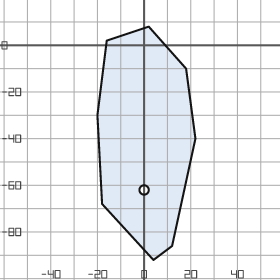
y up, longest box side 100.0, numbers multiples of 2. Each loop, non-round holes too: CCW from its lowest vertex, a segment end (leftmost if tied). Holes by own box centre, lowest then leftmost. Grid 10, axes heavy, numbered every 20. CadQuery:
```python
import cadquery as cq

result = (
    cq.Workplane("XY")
    .moveTo(4.0, -92.0)
    .lineTo(12.0, -86.0)
    .lineTo(22.0, -40.0)
    .lineTo(18.0, -10.0)
    .lineTo(2.0, 8.0)
    .lineTo(-16.0, 2.0)
    .lineTo(-20.0, -30.0)
    .lineTo(-18.0, -68.0)
    .close()
    .moveTo(0.0, -62.0)
    .circle(2.0)
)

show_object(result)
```